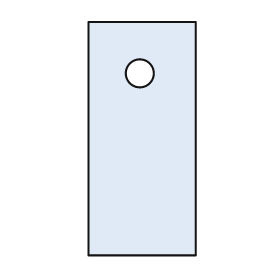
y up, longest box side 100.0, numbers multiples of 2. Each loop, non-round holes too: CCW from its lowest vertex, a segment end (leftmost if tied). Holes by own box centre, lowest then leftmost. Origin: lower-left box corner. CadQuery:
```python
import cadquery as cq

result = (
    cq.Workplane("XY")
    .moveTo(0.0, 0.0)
    .lineTo(46.0, 0.0)
    .lineTo(46.0, 100.0)
    .lineTo(0.0, 100.0)
    .close()
    .moveTo(22.0, 78.0)
    .circle(6.0)
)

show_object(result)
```